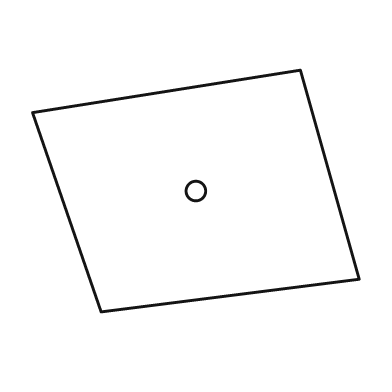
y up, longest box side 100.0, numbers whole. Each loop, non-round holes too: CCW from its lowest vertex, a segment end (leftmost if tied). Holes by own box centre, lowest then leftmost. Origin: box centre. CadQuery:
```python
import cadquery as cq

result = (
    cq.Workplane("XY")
    .moveTo(-29.0, -37.0)
    .lineTo(50.0, -27.0)
    .lineTo(32.0, 37.0)
    .lineTo(-50.0, 24.0)
    .close()
    .moveTo(0.0, 0.0)
    .circle(3.0)
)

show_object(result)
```